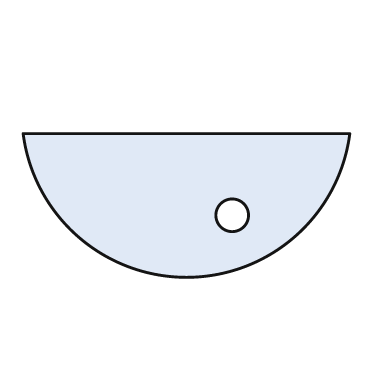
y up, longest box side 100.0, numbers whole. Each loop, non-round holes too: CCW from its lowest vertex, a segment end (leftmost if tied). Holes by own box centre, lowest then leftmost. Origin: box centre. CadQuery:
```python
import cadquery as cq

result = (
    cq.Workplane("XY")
    .moveTo(-50.0, 22.0)
    .threePointArc((0.0, -22.0), (50.0, 22.0))
    .close()
    .moveTo(14.0, -3.0)
    .circle(5.0)
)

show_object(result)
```